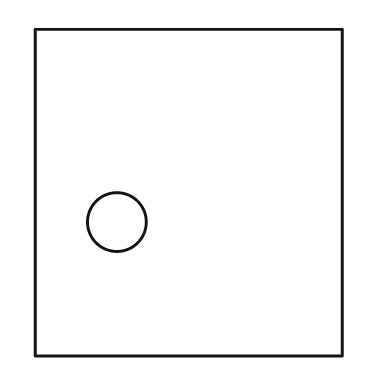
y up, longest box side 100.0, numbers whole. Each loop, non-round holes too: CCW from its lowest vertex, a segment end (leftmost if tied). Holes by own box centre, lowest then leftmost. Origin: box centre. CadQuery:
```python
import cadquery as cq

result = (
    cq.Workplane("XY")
    .moveTo(-47.0, -50.0)
    .lineTo(47.0, -50.0)
    .lineTo(47.0, 50.0)
    .lineTo(-47.0, 50.0)
    .close()
    .moveTo(-22.0, -9.0)
    .circle(9.0)
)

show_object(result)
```